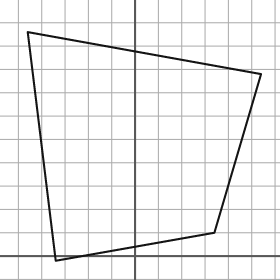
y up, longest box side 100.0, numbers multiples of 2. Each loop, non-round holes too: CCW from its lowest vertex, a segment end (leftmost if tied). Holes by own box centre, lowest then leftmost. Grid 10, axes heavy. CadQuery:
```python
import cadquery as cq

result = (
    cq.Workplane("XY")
    .moveTo(-34.0, -2.0)
    .lineTo(34.0, 10.0)
    .lineTo(54.0, 78.0)
    .lineTo(-46.0, 96.0)
    .close()
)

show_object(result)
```